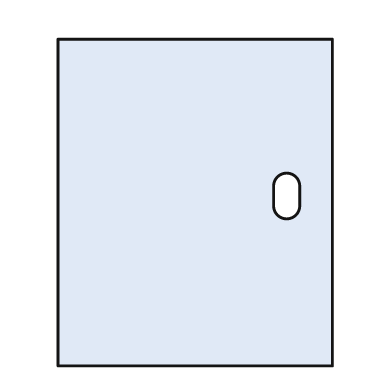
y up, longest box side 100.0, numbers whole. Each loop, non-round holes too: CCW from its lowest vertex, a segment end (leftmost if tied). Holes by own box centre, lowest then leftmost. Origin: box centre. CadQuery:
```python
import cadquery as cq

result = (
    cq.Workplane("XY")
    .moveTo(-42.0, -50.0)
    .lineTo(42.0, -50.0)
    .lineTo(42.0, 50.0)
    .lineTo(-42.0, 50.0)
    .close()
    .moveTo(24.0, -1.0)
    .threePointArc((28.0, -5.0), (32.0, -1.0))
    .lineTo(32.0, 5.0)
    .threePointArc((28.0, 9.0), (24.0, 5.0))
    .close()
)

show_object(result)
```